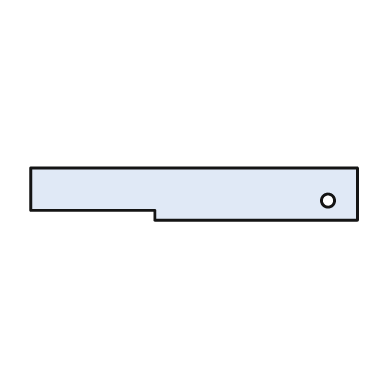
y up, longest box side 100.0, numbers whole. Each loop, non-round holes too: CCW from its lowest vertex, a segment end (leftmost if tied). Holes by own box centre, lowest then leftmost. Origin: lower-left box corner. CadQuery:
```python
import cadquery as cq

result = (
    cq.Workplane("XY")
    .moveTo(38.0, 0.0)
    .lineTo(100.0, 0.0)
    .lineTo(100.0, 16.0)
    .lineTo(0.0, 16.0)
    .lineTo(0.0, 3.0)
    .lineTo(38.0, 3.0)
    .close()
    .moveTo(91.0, 6.0)
    .circle(2.0)
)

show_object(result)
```